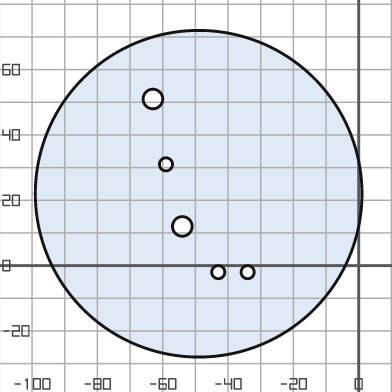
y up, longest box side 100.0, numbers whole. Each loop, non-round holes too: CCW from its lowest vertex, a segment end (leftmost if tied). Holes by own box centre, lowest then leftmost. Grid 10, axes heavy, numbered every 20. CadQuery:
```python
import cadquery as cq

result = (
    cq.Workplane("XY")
    .moveTo(-49.0, 22.0)
    .circle(50.0)
    .moveTo(-43.0, -2.0)
    .circle(2.0)
    .moveTo(-34.0, -2.0)
    .circle(2.0)
    .moveTo(-54.0, 12.0)
    .circle(3.0)
    .moveTo(-59.0, 31.0)
    .circle(2.0)
    .moveTo(-63.0, 51.0)
    .circle(3.0)
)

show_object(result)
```